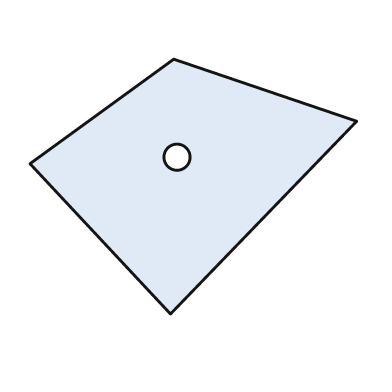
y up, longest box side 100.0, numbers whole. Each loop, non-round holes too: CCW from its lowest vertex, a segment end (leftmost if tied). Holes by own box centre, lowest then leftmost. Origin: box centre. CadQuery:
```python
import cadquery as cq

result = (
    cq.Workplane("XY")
    .moveTo(-7.0, -39.0)
    .lineTo(50.0, 20.0)
    .lineTo(-6.0, 39.0)
    .lineTo(-50.0, 7.0)
    .close()
    .moveTo(-5.0, 9.0)
    .circle(4.0)
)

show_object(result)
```